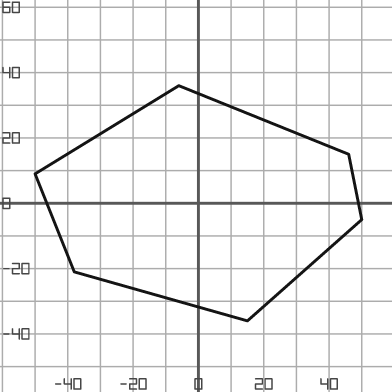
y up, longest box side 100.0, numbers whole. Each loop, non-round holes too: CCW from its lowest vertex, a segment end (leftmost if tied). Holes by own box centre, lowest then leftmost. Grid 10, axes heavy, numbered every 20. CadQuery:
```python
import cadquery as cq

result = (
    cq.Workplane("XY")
    .moveTo(15.0, -36.0)
    .lineTo(50.0, -5.0)
    .lineTo(46.0, 15.0)
    .lineTo(-6.0, 36.0)
    .lineTo(-50.0, 9.0)
    .lineTo(-38.0, -21.0)
    .close()
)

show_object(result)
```